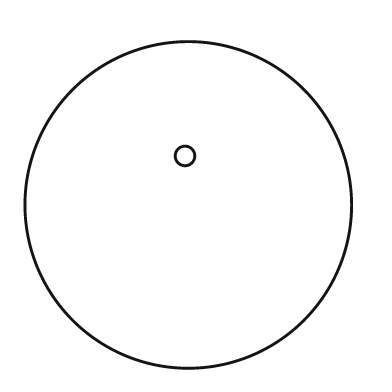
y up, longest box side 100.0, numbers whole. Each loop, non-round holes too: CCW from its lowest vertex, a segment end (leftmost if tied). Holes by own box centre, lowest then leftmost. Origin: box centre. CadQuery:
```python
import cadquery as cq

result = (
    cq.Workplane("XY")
    .moveTo(0.0, 0.0)
    .circle(50.0)
    .moveTo(-1.0, 15.0)
    .circle(3.0)
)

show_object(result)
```